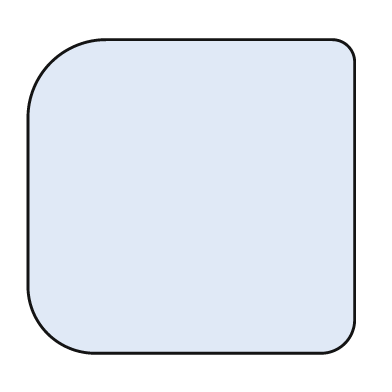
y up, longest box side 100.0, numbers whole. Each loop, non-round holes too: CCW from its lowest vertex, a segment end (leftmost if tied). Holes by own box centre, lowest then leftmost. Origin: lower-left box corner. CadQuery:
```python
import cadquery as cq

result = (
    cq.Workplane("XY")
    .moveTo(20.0, 0.0)
    .lineTo(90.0, 0.0)
    .threePointArc((97.0, 3.0), (100.0, 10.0))
    .lineTo(100.0, 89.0)
    .threePointArc((98.0, 94.0), (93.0, 96.0))
    .lineTo(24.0, 96.0)
    .threePointArc((7.0, 89.0), (0.0, 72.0))
    .lineTo(0.0, 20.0)
    .threePointArc((6.0, 6.0), (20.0, 0.0))
    .close()
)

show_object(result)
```